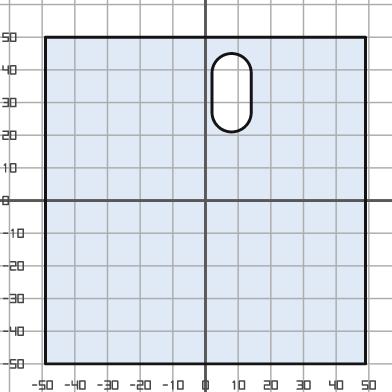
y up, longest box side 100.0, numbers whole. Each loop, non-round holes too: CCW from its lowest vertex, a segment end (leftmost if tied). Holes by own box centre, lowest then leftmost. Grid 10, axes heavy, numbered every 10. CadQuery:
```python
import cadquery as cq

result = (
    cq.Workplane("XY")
    .moveTo(-49.0, -50.0)
    .lineTo(49.0, -50.0)
    .lineTo(49.0, 50.0)
    .lineTo(-49.0, 50.0)
    .close()
    .moveTo(2.0, 27.0)
    .threePointArc((8.0, 21.0), (14.0, 27.0))
    .lineTo(14.0, 39.0)
    .threePointArc((8.0, 45.0), (2.0, 39.0))
    .close()
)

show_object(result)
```